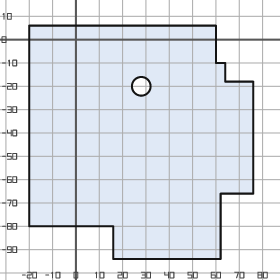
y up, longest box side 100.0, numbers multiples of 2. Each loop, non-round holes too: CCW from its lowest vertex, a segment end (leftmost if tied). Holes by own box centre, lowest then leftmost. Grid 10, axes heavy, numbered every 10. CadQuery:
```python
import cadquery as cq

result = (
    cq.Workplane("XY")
    .moveTo(16.0, -94.0)
    .lineTo(62.0, -94.0)
    .lineTo(62.0, -66.0)
    .lineTo(76.0, -66.0)
    .lineTo(76.0, -18.0)
    .lineTo(64.0, -18.0)
    .lineTo(64.0, -10.0)
    .lineTo(60.0, -10.0)
    .lineTo(60.0, 6.0)
    .lineTo(-20.0, 6.0)
    .lineTo(-20.0, -80.0)
    .lineTo(16.0, -80.0)
    .close()
    .moveTo(28.0, -20.0)
    .circle(4.0)
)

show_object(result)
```